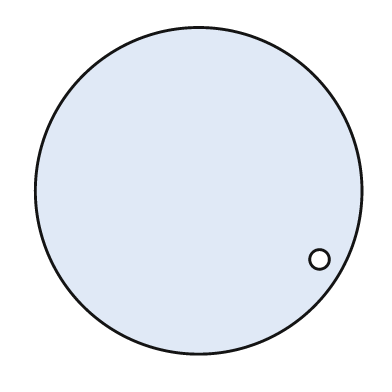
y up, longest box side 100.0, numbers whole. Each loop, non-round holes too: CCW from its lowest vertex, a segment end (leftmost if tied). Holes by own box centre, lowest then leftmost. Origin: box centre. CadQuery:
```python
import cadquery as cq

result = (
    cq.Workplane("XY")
    .moveTo(0.0, 0.0)
    .circle(50.0)
    .moveTo(37.0, -21.0)
    .circle(3.0)
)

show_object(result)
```